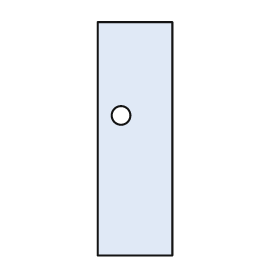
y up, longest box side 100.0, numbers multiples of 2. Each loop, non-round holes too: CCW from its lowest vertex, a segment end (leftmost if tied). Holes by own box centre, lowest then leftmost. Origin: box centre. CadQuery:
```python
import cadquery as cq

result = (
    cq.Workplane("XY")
    .moveTo(-16.0, -50.0)
    .lineTo(16.0, -50.0)
    .lineTo(16.0, 50.0)
    .lineTo(-16.0, 50.0)
    .close()
    .moveTo(-6.0, 10.0)
    .circle(4.0)
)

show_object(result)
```